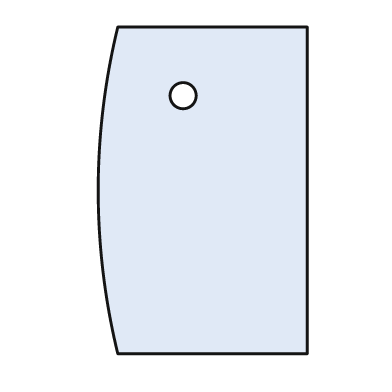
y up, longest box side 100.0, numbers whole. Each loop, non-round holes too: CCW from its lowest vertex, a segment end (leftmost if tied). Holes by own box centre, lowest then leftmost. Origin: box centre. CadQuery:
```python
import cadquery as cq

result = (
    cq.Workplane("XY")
    .moveTo(-26.0, -50.0)
    .lineTo(32.0, -50.0)
    .lineTo(32.0, 50.0)
    .lineTo(-26.0, 50.0)
    .threePointArc((-32.0, 0.0), (-26.0, -50.0))
    .close()
    .moveTo(-6.0, 29.0)
    .circle(4.0)
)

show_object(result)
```